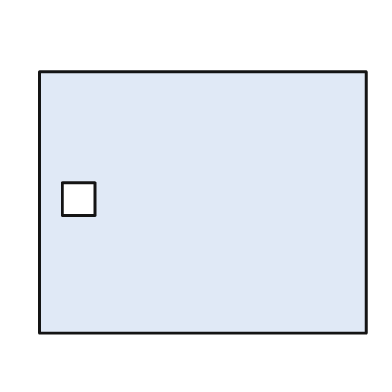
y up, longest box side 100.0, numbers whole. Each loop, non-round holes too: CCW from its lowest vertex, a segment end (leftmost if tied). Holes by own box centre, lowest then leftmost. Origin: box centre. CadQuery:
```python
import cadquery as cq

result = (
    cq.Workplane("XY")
    .moveTo(-50.0, -40.0)
    .lineTo(50.0, -40.0)
    .lineTo(50.0, 40.0)
    .lineTo(-50.0, 40.0)
    .close()
    .moveTo(-43.0, -4.0)
    .lineTo(-33.0, -4.0)
    .lineTo(-33.0, 6.0)
    .lineTo(-43.0, 6.0)
    .close()
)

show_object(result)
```